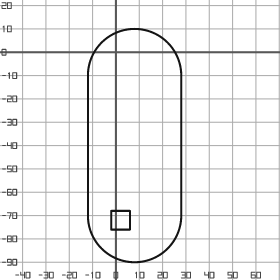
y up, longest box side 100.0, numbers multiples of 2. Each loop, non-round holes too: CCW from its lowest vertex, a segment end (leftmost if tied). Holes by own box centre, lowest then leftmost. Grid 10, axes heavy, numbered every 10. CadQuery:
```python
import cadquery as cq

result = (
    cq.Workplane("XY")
    .moveTo(-12.0, -70.0)
    .threePointArc((8.0, -90.0), (28.0, -70.0))
    .lineTo(28.0, -10.0)
    .threePointArc((8.0, 10.0), (-12.0, -10.0))
    .close()
    .moveTo(-2.0, -76.0)
    .lineTo(6.0, -76.0)
    .lineTo(6.0, -68.0)
    .lineTo(-2.0, -68.0)
    .close()
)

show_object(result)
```